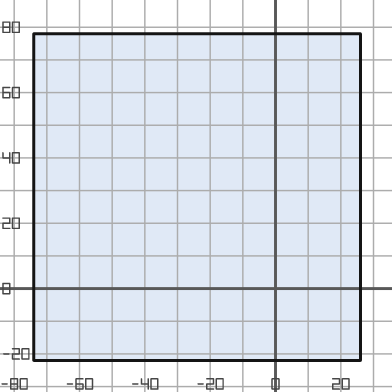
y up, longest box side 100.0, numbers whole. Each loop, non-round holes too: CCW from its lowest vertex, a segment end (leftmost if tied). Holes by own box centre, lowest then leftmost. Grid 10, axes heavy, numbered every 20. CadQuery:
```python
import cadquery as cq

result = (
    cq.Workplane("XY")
    .moveTo(-74.0, -22.0)
    .lineTo(26.0, -22.0)
    .lineTo(26.0, 78.0)
    .lineTo(-74.0, 78.0)
    .close()
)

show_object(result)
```